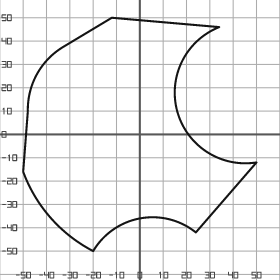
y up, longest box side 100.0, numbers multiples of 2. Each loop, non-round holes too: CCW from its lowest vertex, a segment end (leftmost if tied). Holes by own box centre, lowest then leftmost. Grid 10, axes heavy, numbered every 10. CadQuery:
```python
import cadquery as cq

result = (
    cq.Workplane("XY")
    .moveTo(-20.0, -50.0)
    .threePointArc((0.0, -36.0), (24.0, -42.0))
    .lineTo(50.0, -12.0)
    .threePointArc((16.0, 10.0), (34.0, 46.0))
    .lineTo(-12.0, 50.0)
    .lineTo(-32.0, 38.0)
    .threePointArc((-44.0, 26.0), (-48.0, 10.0))
    .lineTo(-50.0, -16.0)
    .threePointArc((-38.0, -36.0), (-20.0, -50.0))
    .close()
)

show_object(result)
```